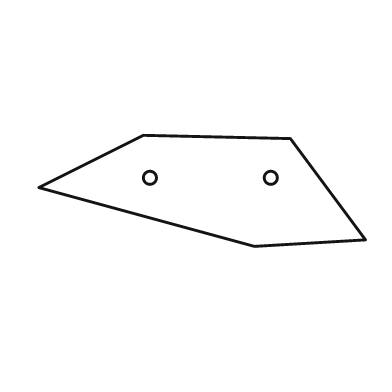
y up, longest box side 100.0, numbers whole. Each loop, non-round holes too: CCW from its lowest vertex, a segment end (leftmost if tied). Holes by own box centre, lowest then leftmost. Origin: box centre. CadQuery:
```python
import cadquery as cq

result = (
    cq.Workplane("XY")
    .moveTo(16.0, -17.0)
    .lineTo(50.0, -15.0)
    .lineTo(27.0, 16.0)
    .lineTo(-18.0, 17.0)
    .lineTo(-50.0, 1.0)
    .close()
    .moveTo(-16.0, 4.0)
    .circle(2.0)
    .moveTo(21.0, 4.0)
    .circle(2.0)
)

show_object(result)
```